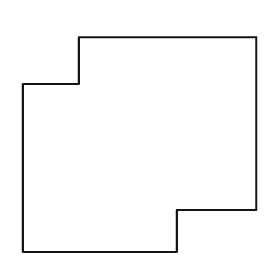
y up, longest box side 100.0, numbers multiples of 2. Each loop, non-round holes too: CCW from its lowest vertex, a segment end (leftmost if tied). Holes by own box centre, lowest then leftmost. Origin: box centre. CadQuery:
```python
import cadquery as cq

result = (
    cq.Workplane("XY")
    .moveTo(-50.0, -46.0)
    .lineTo(16.0, -46.0)
    .lineTo(16.0, -28.0)
    .lineTo(50.0, -28.0)
    .lineTo(50.0, 46.0)
    .lineTo(-26.0, 46.0)
    .lineTo(-26.0, 26.0)
    .lineTo(-50.0, 26.0)
    .close()
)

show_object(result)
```